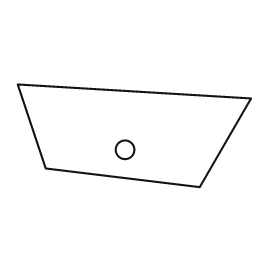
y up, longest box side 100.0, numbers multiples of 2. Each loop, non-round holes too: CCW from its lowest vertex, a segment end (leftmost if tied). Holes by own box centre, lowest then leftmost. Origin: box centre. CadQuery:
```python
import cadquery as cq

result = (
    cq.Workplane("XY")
    .moveTo(28.0, -22.0)
    .lineTo(50.0, 16.0)
    .lineTo(-50.0, 22.0)
    .lineTo(-38.0, -14.0)
    .close()
    .moveTo(-4.0, -6.0)
    .circle(4.0)
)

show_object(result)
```